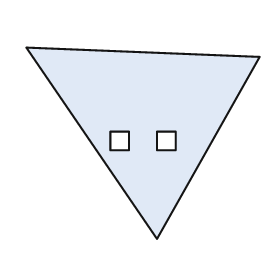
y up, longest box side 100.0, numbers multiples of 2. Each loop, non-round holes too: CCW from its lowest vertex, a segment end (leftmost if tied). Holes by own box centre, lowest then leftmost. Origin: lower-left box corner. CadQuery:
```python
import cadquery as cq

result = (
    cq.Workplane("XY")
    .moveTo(56.0, 0.0)
    .lineTo(100.0, 78.0)
    .lineTo(0.0, 82.0)
    .close()
    .moveTo(36.0, 38.0)
    .lineTo(44.0, 38.0)
    .lineTo(44.0, 46.0)
    .lineTo(36.0, 46.0)
    .close()
    .moveTo(56.0, 38.0)
    .lineTo(64.0, 38.0)
    .lineTo(64.0, 46.0)
    .lineTo(56.0, 46.0)
    .close()
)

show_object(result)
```